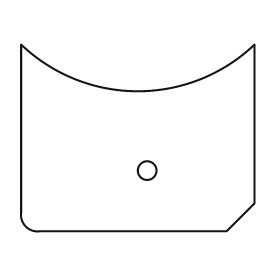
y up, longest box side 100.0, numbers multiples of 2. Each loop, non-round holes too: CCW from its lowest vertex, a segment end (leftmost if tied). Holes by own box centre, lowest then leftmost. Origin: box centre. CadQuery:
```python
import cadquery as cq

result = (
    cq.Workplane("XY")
    .moveTo(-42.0, -40.0)
    .lineTo(38.0, -40.0)
    .lineTo(50.0, -28.0)
    .lineTo(50.0, 40.0)
    .threePointArc((0.0, 20.0), (-50.0, 40.0))
    .lineTo(-50.0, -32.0)
    .threePointArc((-48.0, -38.0), (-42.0, -40.0))
    .close()
    .moveTo(4.0, -14.0)
    .circle(4.0)
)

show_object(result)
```